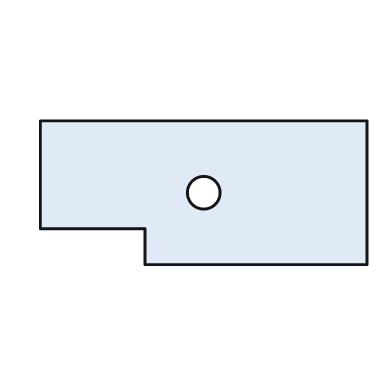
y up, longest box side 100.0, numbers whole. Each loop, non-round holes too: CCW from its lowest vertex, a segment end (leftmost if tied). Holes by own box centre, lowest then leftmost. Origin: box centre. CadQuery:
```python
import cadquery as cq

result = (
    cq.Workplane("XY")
    .moveTo(-18.0, -22.0)
    .lineTo(50.0, -22.0)
    .lineTo(50.0, 22.0)
    .lineTo(-50.0, 22.0)
    .lineTo(-50.0, -11.0)
    .lineTo(-18.0, -11.0)
    .close()
    .moveTo(0.0, 0.0)
    .circle(5.0)
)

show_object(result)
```